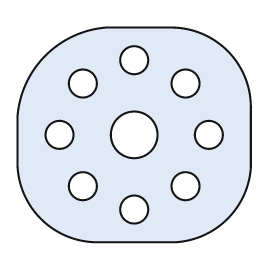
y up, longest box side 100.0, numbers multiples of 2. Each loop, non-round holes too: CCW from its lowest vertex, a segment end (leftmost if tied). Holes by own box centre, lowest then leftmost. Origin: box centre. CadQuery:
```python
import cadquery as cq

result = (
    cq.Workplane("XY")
    .moveTo(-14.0, -46.0)
    .lineTo(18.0, -46.0)
    .threePointArc((40.0, -36.0), (50.0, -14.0))
    .lineTo(50.0, 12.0)
    .threePointArc((40.0, 36.0), (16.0, 46.0))
    .lineTo(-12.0, 46.0)
    .threePointArc((-38.0, 34.0), (-50.0, 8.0))
    .lineTo(-50.0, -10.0)
    .threePointArc((-40.0, -36.0), (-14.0, -46.0))
    .close()
    .moveTo(0.0, -32.0)
    .circle(6.0)
    .moveTo(-22.0, -22.0)
    .circle(6.0)
    .moveTo(22.0, -22.0)
    .circle(6.0)
    .moveTo(-32.0, 0.0)
    .circle(6.0)
    .moveTo(0.0, 0.0)
    .circle(10.0)
    .moveTo(32.0, 0.0)
    .circle(6.0)
    .moveTo(-22.0, 22.0)
    .circle(6.0)
    .moveTo(22.0, 22.0)
    .circle(6.0)
    .moveTo(0.0, 32.0)
    .circle(6.0)
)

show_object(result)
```